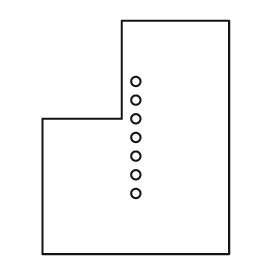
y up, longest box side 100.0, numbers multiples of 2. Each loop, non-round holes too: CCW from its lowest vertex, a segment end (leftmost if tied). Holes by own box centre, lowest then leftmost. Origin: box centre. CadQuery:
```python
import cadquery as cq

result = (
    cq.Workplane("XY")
    .moveTo(-40.0, -50.0)
    .lineTo(40.0, -50.0)
    .lineTo(40.0, 50.0)
    .lineTo(-6.0, 50.0)
    .lineTo(-6.0, 8.0)
    .lineTo(-40.0, 8.0)
    .close()
    .moveTo(0.0, -24.0)
    .circle(2.0)
    .moveTo(0.0, -16.0)
    .circle(2.0)
    .moveTo(0.0, -8.0)
    .circle(2.0)
    .moveTo(0.0, 0.0)
    .circle(2.0)
    .moveTo(0.0, 8.0)
    .circle(2.0)
    .moveTo(0.0, 16.0)
    .circle(2.0)
    .moveTo(0.0, 24.0)
    .circle(2.0)
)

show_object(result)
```